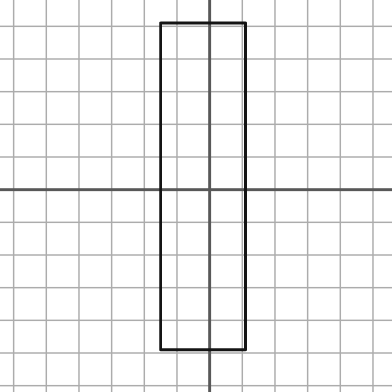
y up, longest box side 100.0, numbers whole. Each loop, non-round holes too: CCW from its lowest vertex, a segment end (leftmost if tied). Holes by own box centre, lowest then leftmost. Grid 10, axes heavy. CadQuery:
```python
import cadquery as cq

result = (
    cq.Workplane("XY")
    .moveTo(-15.0, -49.0)
    .lineTo(11.0, -49.0)
    .lineTo(11.0, 51.0)
    .lineTo(-15.0, 51.0)
    .close()
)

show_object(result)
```